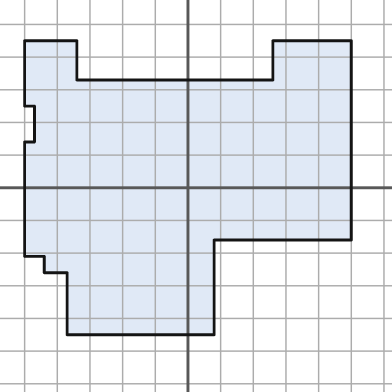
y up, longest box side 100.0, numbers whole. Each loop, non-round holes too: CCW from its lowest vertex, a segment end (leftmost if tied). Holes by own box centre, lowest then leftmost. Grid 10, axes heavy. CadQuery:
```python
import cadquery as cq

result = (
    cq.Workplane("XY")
    .moveTo(-37.0, -45.0)
    .lineTo(8.0, -45.0)
    .lineTo(8.0, -16.0)
    .lineTo(50.0, -16.0)
    .lineTo(50.0, 45.0)
    .lineTo(26.0, 45.0)
    .lineTo(26.0, 33.0)
    .lineTo(-34.0, 33.0)
    .lineTo(-34.0, 45.0)
    .lineTo(-50.0, 45.0)
    .lineTo(-50.0, 25.0)
    .lineTo(-47.0, 25.0)
    .lineTo(-47.0, 14.0)
    .lineTo(-50.0, 14.0)
    .lineTo(-50.0, -21.0)
    .lineTo(-44.0, -21.0)
    .lineTo(-44.0, -26.0)
    .lineTo(-37.0, -26.0)
    .close()
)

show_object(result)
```